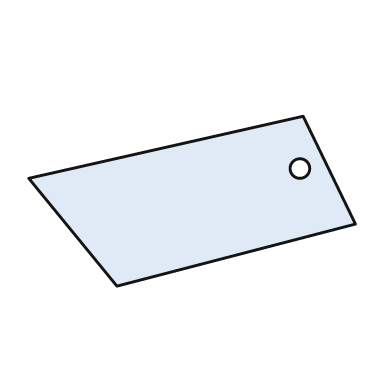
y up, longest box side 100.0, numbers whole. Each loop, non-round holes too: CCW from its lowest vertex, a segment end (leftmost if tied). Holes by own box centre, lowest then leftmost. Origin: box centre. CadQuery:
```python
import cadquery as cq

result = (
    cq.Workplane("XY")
    .moveTo(-23.0, -26.0)
    .lineTo(50.0, -7.0)
    .lineTo(34.0, 26.0)
    .lineTo(-50.0, 7.0)
    .close()
    .moveTo(33.0, 10.0)
    .circle(3.0)
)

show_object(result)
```